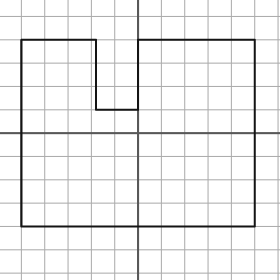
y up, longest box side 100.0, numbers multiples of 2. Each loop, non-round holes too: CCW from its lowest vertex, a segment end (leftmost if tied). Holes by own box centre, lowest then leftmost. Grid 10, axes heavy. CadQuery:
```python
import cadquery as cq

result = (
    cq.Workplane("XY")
    .moveTo(-50.0, -40.0)
    .lineTo(50.0, -40.0)
    .lineTo(50.0, 40.0)
    .lineTo(0.0, 40.0)
    .lineTo(0.0, 10.0)
    .lineTo(-18.0, 10.0)
    .lineTo(-18.0, 40.0)
    .lineTo(-50.0, 40.0)
    .close()
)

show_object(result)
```